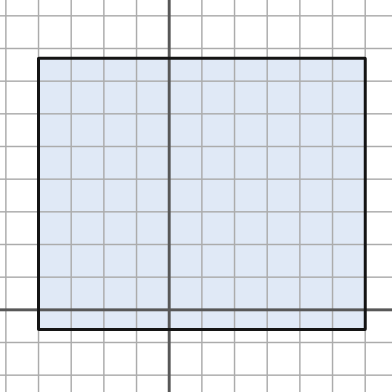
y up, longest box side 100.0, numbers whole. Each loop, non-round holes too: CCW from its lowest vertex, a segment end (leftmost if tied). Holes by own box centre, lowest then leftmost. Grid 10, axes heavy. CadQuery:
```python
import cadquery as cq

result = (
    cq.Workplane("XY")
    .moveTo(-40.0, -6.0)
    .lineTo(60.0, -6.0)
    .lineTo(60.0, 77.0)
    .lineTo(-40.0, 77.0)
    .close()
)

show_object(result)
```